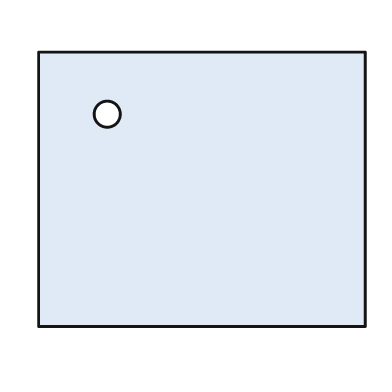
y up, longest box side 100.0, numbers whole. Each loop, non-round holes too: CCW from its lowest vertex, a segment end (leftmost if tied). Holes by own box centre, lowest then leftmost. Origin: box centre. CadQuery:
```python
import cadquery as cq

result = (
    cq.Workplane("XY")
    .moveTo(-50.0, -42.0)
    .lineTo(50.0, -42.0)
    .lineTo(50.0, 42.0)
    .lineTo(-50.0, 42.0)
    .close()
    .moveTo(-29.0, 23.0)
    .circle(4.0)
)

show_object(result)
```